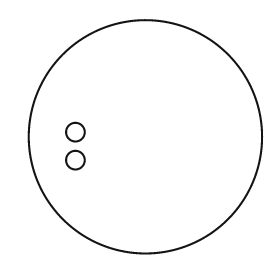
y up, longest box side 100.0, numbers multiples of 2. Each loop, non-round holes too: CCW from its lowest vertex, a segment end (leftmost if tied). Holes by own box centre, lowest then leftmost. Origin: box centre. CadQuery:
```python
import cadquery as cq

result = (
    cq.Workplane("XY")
    .moveTo(0.0, 0.0)
    .circle(50.0)
    .moveTo(-30.0, -10.0)
    .circle(4.0)
    .moveTo(-30.0, 2.0)
    .circle(4.0)
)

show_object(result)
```